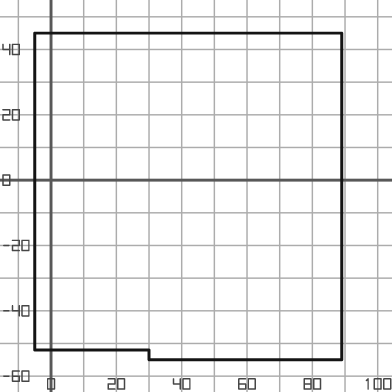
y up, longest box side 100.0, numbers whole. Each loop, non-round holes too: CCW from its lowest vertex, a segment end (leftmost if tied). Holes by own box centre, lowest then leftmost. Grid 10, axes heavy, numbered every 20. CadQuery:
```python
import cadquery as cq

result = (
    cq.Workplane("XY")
    .moveTo(30.0, -55.0)
    .lineTo(89.0, -55.0)
    .lineTo(89.0, 45.0)
    .lineTo(-5.0, 45.0)
    .lineTo(-5.0, -52.0)
    .lineTo(30.0, -52.0)
    .close()
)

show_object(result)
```